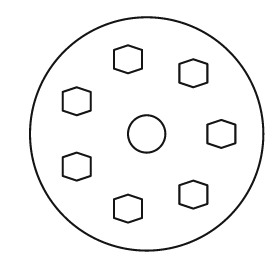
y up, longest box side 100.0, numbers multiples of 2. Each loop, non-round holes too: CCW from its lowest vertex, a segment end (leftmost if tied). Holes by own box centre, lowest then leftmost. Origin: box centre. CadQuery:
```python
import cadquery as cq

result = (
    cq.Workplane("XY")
    .moveTo(0.0, 0.0)
    .circle(50.0)
    .moveTo(-8.0, -38.0)
    .lineTo(-2.0, -36.0)
    .lineTo(-2.0, -28.0)
    .lineTo(-8.0, -26.0)
    .lineTo(-14.0, -28.0)
    .lineTo(-14.0, -36.0)
    .close()
    .moveTo(20.0, -32.0)
    .lineTo(26.0, -30.0)
    .lineTo(26.0, -22.0)
    .lineTo(20.0, -20.0)
    .lineTo(14.0, -22.0)
    .lineTo(14.0, -30.0)
    .close()
    .moveTo(-30.0, -20.0)
    .lineTo(-24.0, -18.0)
    .lineTo(-24.0, -10.0)
    .lineTo(-30.0, -8.0)
    .lineTo(-36.0, -10.0)
    .lineTo(-36.0, -18.0)
    .close()
    .moveTo(0.0, 0.0)
    .circle(8.0)
    .moveTo(32.0, -6.0)
    .lineTo(38.0, -4.0)
    .lineTo(38.0, 4.0)
    .lineTo(32.0, 6.0)
    .lineTo(26.0, 4.0)
    .lineTo(26.0, -4.0)
    .close()
    .moveTo(-30.0, 8.0)
    .lineTo(-24.0, 10.0)
    .lineTo(-24.0, 18.0)
    .lineTo(-30.0, 20.0)
    .lineTo(-36.0, 18.0)
    .lineTo(-36.0, 10.0)
    .close()
    .moveTo(20.0, 20.0)
    .lineTo(26.0, 22.0)
    .lineTo(26.0, 30.0)
    .lineTo(20.0, 32.0)
    .lineTo(14.0, 30.0)
    .lineTo(14.0, 22.0)
    .close()
    .moveTo(-8.0, 26.0)
    .lineTo(-2.0, 28.0)
    .lineTo(-2.0, 36.0)
    .lineTo(-8.0, 38.0)
    .lineTo(-14.0, 36.0)
    .lineTo(-14.0, 28.0)
    .close()
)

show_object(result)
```